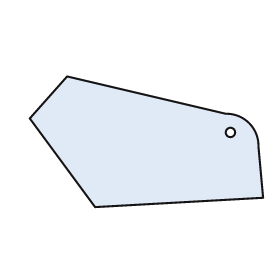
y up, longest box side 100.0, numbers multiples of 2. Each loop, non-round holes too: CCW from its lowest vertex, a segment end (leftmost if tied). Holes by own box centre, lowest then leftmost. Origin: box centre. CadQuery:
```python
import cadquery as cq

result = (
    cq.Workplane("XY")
    .moveTo(-22.0, -28.0)
    .lineTo(50.0, -24.0)
    .lineTo(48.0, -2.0)
    .threePointArc((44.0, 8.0), (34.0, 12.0))
    .lineTo(-34.0, 28.0)
    .lineTo(-50.0, 10.0)
    .close()
    .moveTo(36.0, 4.0)
    .circle(2.0)
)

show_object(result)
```